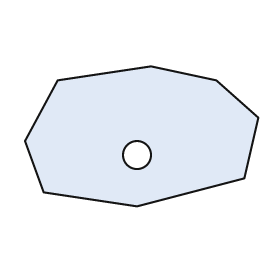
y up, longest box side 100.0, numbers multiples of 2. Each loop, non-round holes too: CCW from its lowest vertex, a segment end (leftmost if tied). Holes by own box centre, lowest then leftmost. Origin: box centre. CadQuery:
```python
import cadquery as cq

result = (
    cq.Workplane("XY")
    .moveTo(-2.0, -30.0)
    .lineTo(44.0, -18.0)
    .lineTo(50.0, 8.0)
    .lineTo(32.0, 24.0)
    .lineTo(4.0, 30.0)
    .lineTo(-36.0, 24.0)
    .lineTo(-50.0, -2.0)
    .lineTo(-42.0, -24.0)
    .close()
    .moveTo(-2.0, -8.0)
    .circle(6.0)
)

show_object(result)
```